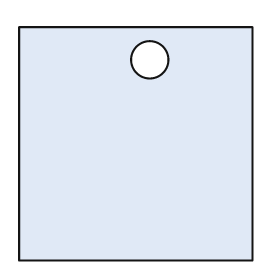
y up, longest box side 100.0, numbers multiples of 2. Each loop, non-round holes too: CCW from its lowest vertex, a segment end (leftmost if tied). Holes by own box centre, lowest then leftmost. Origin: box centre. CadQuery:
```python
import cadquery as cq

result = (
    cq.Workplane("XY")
    .moveTo(-50.0, -50.0)
    .lineTo(50.0, -50.0)
    .lineTo(50.0, 50.0)
    .lineTo(-50.0, 50.0)
    .close()
    .moveTo(6.0, 36.0)
    .circle(8.0)
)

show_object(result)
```